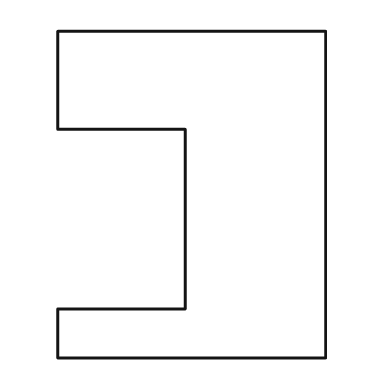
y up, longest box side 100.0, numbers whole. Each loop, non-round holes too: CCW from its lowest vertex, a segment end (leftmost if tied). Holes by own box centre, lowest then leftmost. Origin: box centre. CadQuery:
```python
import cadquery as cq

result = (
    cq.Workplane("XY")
    .moveTo(-41.0, -50.0)
    .lineTo(41.0, -50.0)
    .lineTo(41.0, 50.0)
    .lineTo(-41.0, 50.0)
    .lineTo(-41.0, 20.0)
    .lineTo(-2.0, 20.0)
    .lineTo(-2.0, -35.0)
    .lineTo(-41.0, -35.0)
    .close()
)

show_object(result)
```